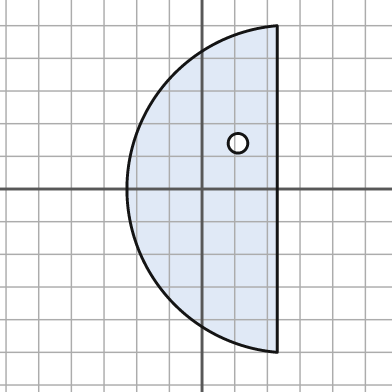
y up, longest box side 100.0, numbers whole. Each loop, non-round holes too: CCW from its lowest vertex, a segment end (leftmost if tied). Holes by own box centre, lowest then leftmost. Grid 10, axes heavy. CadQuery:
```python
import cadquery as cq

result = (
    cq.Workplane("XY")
    .moveTo(23.0, -50.0)
    .lineTo(23.0, 50.0)
    .threePointArc((-23.0, 0.0), (23.0, -50.0))
    .close()
    .moveTo(11.0, 14.0)
    .circle(3.0)
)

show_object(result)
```